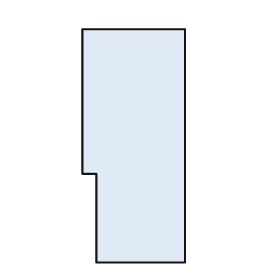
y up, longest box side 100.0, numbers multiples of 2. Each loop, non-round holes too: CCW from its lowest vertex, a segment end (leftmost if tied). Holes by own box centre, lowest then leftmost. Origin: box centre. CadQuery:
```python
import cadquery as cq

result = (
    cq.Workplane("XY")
    .moveTo(-16.0, -50.0)
    .lineTo(22.0, -50.0)
    .lineTo(22.0, 50.0)
    .lineTo(-22.0, 50.0)
    .lineTo(-22.0, -12.0)
    .lineTo(-16.0, -12.0)
    .close()
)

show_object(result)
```